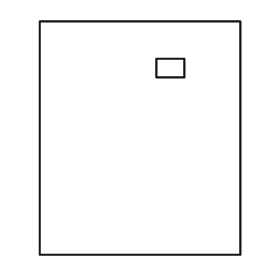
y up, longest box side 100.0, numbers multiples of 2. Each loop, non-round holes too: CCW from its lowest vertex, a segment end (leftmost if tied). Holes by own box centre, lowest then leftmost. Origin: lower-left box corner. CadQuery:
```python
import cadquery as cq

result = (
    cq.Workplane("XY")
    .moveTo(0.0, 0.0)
    .lineTo(86.0, 0.0)
    .lineTo(86.0, 100.0)
    .lineTo(0.0, 100.0)
    .close()
    .moveTo(50.0, 76.0)
    .lineTo(62.0, 76.0)
    .lineTo(62.0, 84.0)
    .lineTo(50.0, 84.0)
    .close()
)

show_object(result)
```